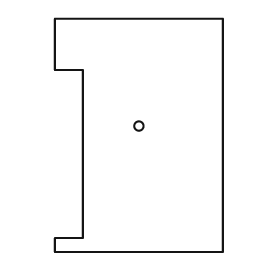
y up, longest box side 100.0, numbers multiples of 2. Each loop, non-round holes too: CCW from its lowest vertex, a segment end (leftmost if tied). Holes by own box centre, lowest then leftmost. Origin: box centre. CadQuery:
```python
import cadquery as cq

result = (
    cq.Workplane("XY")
    .moveTo(-36.0, -50.0)
    .lineTo(36.0, -50.0)
    .lineTo(36.0, 50.0)
    .lineTo(-36.0, 50.0)
    .lineTo(-36.0, 28.0)
    .lineTo(-24.0, 28.0)
    .lineTo(-24.0, -44.0)
    .lineTo(-36.0, -44.0)
    .close()
    .moveTo(0.0, 4.0)
    .circle(2.0)
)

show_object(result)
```